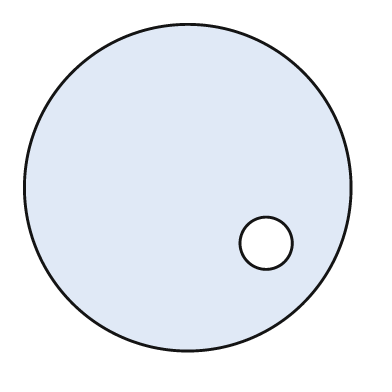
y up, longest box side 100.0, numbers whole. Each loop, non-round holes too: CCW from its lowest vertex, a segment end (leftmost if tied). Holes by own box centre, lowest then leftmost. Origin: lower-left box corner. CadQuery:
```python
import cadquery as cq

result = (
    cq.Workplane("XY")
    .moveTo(50.0, 50.0)
    .circle(50.0)
    .moveTo(74.0, 33.0)
    .circle(8.0)
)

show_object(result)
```